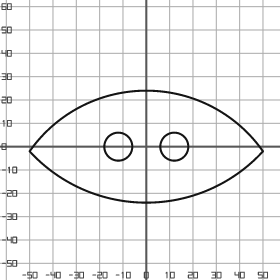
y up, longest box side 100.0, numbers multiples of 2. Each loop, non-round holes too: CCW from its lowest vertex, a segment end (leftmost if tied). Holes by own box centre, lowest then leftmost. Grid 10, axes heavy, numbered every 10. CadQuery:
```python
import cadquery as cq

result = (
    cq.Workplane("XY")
    .moveTo(-50.0, -2.0)
    .threePointArc((0.0, -24.0), (50.0, -2.0))
    .threePointArc((0.0, 24.0), (-50.0, -2.0))
    .close()
    .moveTo(-12.0, 0.0)
    .circle(6.0)
    .moveTo(12.0, 0.0)
    .circle(6.0)
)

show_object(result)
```